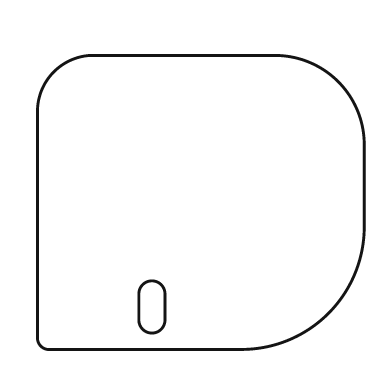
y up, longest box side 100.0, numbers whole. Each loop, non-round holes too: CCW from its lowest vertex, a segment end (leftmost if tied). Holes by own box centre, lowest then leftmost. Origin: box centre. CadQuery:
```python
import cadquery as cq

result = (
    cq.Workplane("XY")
    .moveTo(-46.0, -45.0)
    .lineTo(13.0, -45.0)
    .threePointArc((39.0, -34.0), (50.0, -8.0))
    .lineTo(50.0, 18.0)
    .threePointArc((42.0, 37.0), (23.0, 45.0))
    .lineTo(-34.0, 45.0)
    .threePointArc((-45.0, 40.0), (-50.0, 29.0))
    .lineTo(-50.0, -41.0)
    .threePointArc((-49.0, -44.0), (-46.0, -45.0))
    .close()
    .moveTo(-19.0, -36.0)
    .threePointArc((-15.0, -40.0), (-11.0, -36.0))
    .lineTo(-11.0, -28.0)
    .threePointArc((-15.0, -24.0), (-19.0, -28.0))
    .close()
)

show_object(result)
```